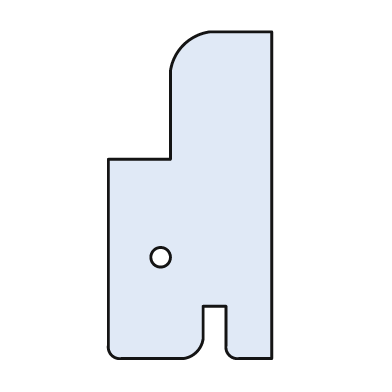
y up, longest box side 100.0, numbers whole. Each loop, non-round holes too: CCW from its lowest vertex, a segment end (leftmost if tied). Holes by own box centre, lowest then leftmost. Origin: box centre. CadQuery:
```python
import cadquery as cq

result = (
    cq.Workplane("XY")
    .moveTo(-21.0, -50.0)
    .lineTo(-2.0, -50.0)
    .threePointArc((2.0, -48.0), (4.0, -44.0))
    .lineTo(4.0, -34.0)
    .lineTo(11.0, -34.0)
    .lineTo(11.0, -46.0)
    .threePointArc((12.0, -49.0), (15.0, -50.0))
    .lineTo(25.0, -50.0)
    .lineTo(25.0, 50.0)
    .lineTo(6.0, 50.0)
    .threePointArc((-2.0, 46.0), (-6.0, 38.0))
    .lineTo(-6.0, 11.0)
    .lineTo(-25.0, 11.0)
    .lineTo(-25.0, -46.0)
    .threePointArc((-24.0, -49.0), (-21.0, -50.0))
    .close()
    .moveTo(-9.0, -19.0)
    .circle(3.0)
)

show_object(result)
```